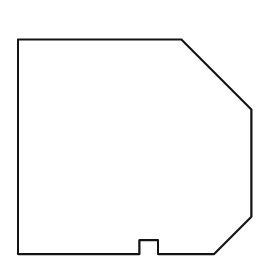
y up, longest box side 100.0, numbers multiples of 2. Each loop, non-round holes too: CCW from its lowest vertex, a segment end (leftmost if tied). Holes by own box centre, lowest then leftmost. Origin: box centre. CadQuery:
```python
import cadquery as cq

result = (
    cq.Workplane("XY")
    .moveTo(-50.0, -46.0)
    .lineTo(2.0, -46.0)
    .lineTo(2.0, -40.0)
    .lineTo(10.0, -40.0)
    .lineTo(10.0, -46.0)
    .lineTo(34.0, -46.0)
    .lineTo(50.0, -30.0)
    .lineTo(50.0, 16.0)
    .lineTo(20.0, 46.0)
    .lineTo(-50.0, 46.0)
    .close()
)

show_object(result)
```